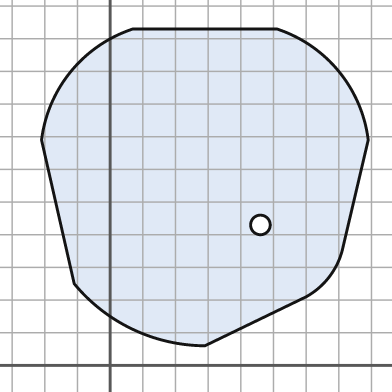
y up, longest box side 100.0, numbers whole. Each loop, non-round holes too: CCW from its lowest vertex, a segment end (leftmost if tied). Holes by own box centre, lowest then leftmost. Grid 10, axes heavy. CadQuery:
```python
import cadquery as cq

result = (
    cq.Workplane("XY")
    .moveTo(29.0, 6.0)
    .lineTo(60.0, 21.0)
    .threePointArc((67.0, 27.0), (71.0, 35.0))
    .lineTo(79.0, 69.0)
    .threePointArc((70.0, 90.0), (51.0, 103.0))
    .lineTo(7.0, 103.0)
    .threePointArc((-12.0, 90.0), (-21.0, 69.0))
    .lineTo(-11.0, 25.0)
    .threePointArc((7.0, 11.0), (29.0, 6.0))
    .close()
    .moveTo(46.0, 43.0)
    .circle(3.0)
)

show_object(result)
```